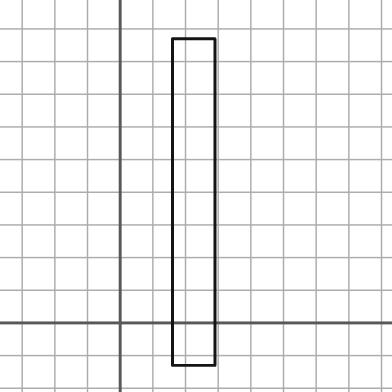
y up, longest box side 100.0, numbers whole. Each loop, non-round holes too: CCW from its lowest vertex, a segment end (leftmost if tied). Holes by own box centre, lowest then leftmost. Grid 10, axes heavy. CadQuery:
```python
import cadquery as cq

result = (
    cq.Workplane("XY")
    .moveTo(16.0, -13.0)
    .lineTo(29.0, -13.0)
    .lineTo(29.0, 87.0)
    .lineTo(16.0, 87.0)
    .close()
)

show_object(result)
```